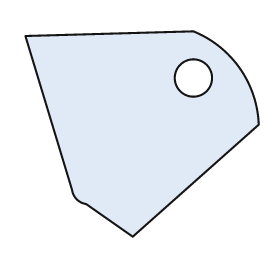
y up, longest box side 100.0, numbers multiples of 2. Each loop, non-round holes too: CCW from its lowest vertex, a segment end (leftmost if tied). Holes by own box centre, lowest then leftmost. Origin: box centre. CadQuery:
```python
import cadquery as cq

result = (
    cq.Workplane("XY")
    .moveTo(-4.0, -44.0)
    .lineTo(50.0, 4.0)
    .threePointArc((42.0, 28.0), (22.0, 44.0))
    .lineTo(-50.0, 42.0)
    .lineTo(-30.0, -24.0)
    .threePointArc((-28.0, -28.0), (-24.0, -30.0))
    .close()
    .moveTo(22.0, 24.0)
    .circle(8.0)
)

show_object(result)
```